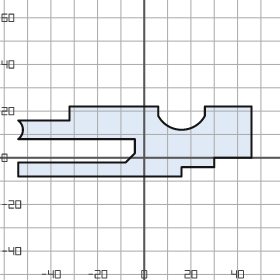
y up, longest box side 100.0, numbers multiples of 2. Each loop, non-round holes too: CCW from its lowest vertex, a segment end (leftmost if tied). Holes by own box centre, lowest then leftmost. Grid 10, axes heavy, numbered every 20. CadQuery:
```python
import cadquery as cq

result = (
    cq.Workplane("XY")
    .moveTo(-54.0, -8.0)
    .lineTo(16.0, -8.0)
    .lineTo(16.0, -4.0)
    .lineTo(30.0, -4.0)
    .lineTo(30.0, 0.0)
    .lineTo(46.0, 0.0)
    .lineTo(46.0, 22.0)
    .lineTo(26.0, 22.0)
    .lineTo(26.0, 18.0)
    .threePointArc((16.0, 12.0), (6.0, 18.0))
    .lineTo(6.0, 22.0)
    .lineTo(-32.0, 22.0)
    .lineTo(-32.0, 16.0)
    .lineTo(-54.0, 16.0)
    .threePointArc((-52.0, 12.0), (-54.0, 8.0))
    .lineTo(-4.0, 8.0)
    .lineTo(-4.0, 2.0)
    .lineTo(-8.0, -2.0)
    .lineTo(-54.0, -2.0)
    .close()
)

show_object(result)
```